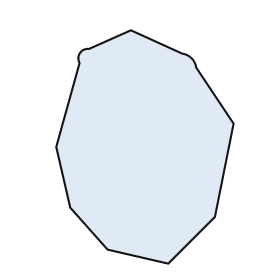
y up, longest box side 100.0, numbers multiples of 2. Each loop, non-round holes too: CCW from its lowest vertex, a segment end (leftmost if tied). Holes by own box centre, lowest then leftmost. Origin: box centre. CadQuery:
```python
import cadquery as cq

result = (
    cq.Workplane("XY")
    .moveTo(10.0, -50.0)
    .lineTo(30.0, -30.0)
    .lineTo(38.0, 10.0)
    .lineTo(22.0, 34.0)
    .threePointArc((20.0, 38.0), (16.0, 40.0))
    .lineTo(-6.0, 50.0)
    .lineTo(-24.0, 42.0)
    .threePointArc((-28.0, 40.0), (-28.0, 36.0))
    .lineTo(-38.0, 0.0)
    .lineTo(-32.0, -26.0)
    .lineTo(-16.0, -44.0)
    .close()
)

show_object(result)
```